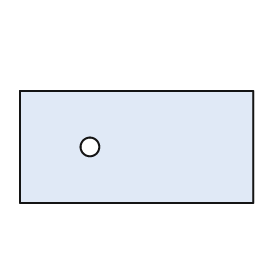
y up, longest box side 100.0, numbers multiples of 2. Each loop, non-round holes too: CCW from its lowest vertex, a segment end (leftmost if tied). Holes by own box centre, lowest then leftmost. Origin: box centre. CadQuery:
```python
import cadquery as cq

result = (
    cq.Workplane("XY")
    .moveTo(-50.0, -24.0)
    .lineTo(50.0, -24.0)
    .lineTo(50.0, 24.0)
    .lineTo(-50.0, 24.0)
    .close()
    .moveTo(-20.0, 0.0)
    .circle(4.0)
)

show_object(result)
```